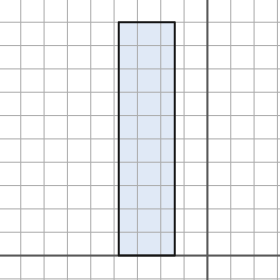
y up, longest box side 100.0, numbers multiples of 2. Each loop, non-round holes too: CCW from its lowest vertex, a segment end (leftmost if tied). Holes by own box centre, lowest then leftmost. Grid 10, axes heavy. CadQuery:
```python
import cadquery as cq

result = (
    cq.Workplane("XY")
    .moveTo(-38.0, 0.0)
    .lineTo(-14.0, 0.0)
    .lineTo(-14.0, 100.0)
    .lineTo(-38.0, 100.0)
    .close()
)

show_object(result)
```